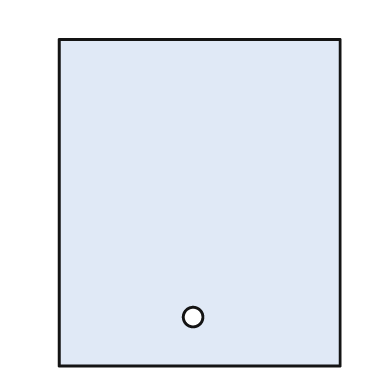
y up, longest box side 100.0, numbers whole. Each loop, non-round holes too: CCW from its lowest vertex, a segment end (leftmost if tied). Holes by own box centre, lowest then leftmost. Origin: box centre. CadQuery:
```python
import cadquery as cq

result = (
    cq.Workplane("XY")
    .moveTo(-43.0, -50.0)
    .lineTo(43.0, -50.0)
    .lineTo(43.0, 50.0)
    .lineTo(-43.0, 50.0)
    .close()
    .moveTo(-2.0, -35.0)
    .circle(3.0)
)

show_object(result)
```